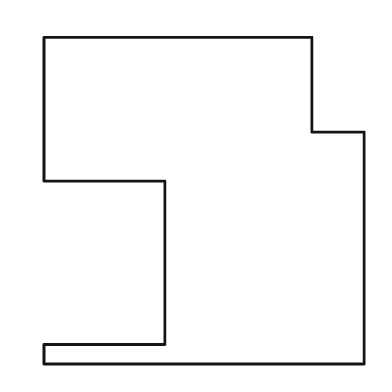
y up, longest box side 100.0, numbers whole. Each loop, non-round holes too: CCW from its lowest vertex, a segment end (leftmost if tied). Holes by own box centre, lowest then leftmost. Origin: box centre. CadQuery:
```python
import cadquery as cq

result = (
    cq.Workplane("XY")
    .moveTo(-49.0, -50.0)
    .lineTo(49.0, -50.0)
    .lineTo(49.0, 21.0)
    .lineTo(33.0, 21.0)
    .lineTo(33.0, 50.0)
    .lineTo(-49.0, 50.0)
    .lineTo(-49.0, 6.0)
    .lineTo(-12.0, 6.0)
    .lineTo(-12.0, -44.0)
    .lineTo(-49.0, -44.0)
    .close()
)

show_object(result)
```